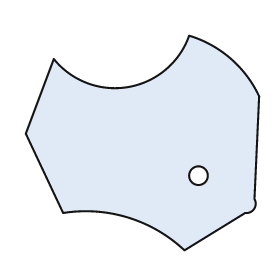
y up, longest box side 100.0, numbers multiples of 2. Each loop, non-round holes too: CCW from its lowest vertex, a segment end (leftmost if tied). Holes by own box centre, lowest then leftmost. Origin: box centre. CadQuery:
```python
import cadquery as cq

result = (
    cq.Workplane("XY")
    .moveTo(18.0, -46.0)
    .lineTo(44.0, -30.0)
    .threePointArc((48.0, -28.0), (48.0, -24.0))
    .lineTo(50.0, 20.0)
    .threePointArc((38.0, 36.0), (20.0, 46.0))
    .threePointArc((-6.0, 24.0), (-38.0, 36.0))
    .lineTo(-50.0, 4.0)
    .lineTo(-34.0, -30.0)
    .threePointArc((-6.0, -32.0), (18.0, -46.0))
    .close()
    .moveTo(24.0, -14.0)
    .circle(4.0)
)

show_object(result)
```